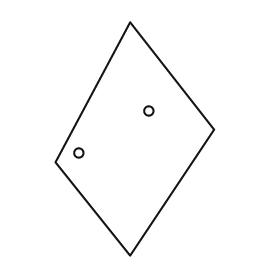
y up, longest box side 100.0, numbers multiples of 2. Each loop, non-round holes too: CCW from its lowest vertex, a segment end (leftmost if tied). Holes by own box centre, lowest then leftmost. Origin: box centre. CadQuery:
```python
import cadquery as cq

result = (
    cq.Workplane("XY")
    .moveTo(-2.0, -50.0)
    .lineTo(34.0, 4.0)
    .lineTo(-2.0, 50.0)
    .lineTo(-34.0, -10.0)
    .close()
    .moveTo(-24.0, -6.0)
    .circle(2.0)
    .moveTo(6.0, 12.0)
    .circle(2.0)
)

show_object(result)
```